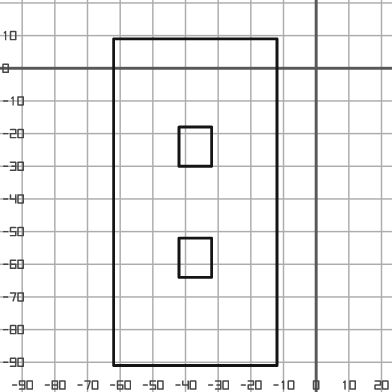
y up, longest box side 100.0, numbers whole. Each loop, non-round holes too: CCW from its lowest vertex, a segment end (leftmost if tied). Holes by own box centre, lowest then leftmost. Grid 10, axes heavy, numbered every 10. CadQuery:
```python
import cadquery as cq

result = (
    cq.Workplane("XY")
    .moveTo(-62.0, -91.0)
    .lineTo(-12.0, -91.0)
    .lineTo(-12.0, 9.0)
    .lineTo(-62.0, 9.0)
    .close()
    .moveTo(-42.0, -64.0)
    .lineTo(-32.0, -64.0)
    .lineTo(-32.0, -52.0)
    .lineTo(-42.0, -52.0)
    .close()
    .moveTo(-42.0, -30.0)
    .lineTo(-32.0, -30.0)
    .lineTo(-32.0, -18.0)
    .lineTo(-42.0, -18.0)
    .close()
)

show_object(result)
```